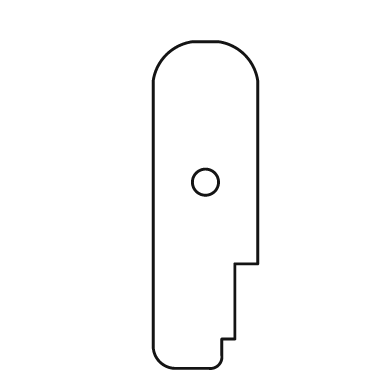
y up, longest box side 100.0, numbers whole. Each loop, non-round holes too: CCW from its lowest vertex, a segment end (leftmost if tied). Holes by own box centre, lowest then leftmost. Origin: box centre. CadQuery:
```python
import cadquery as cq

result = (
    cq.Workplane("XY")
    .moveTo(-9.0, -50.0)
    .lineTo(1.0, -50.0)
    .threePointArc((4.0, -49.0), (5.0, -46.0))
    .lineTo(5.0, -41.0)
    .lineTo(9.0, -41.0)
    .lineTo(9.0, -18.0)
    .lineTo(16.0, -18.0)
    .lineTo(16.0, 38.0)
    .threePointArc((12.0, 46.0), (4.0, 50.0))
    .lineTo(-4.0, 50.0)
    .threePointArc((-12.0, 46.0), (-16.0, 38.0))
    .lineTo(-16.0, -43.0)
    .threePointArc((-14.0, -48.0), (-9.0, -50.0))
    .close()
    .moveTo(0.0, 7.0)
    .circle(4.0)
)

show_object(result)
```